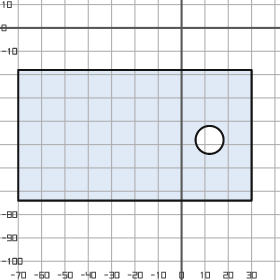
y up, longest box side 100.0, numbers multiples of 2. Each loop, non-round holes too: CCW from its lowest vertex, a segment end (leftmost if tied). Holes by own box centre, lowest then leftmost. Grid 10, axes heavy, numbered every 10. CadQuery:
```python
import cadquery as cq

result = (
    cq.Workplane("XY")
    .moveTo(-70.0, -74.0)
    .lineTo(30.0, -74.0)
    .lineTo(30.0, -18.0)
    .lineTo(-70.0, -18.0)
    .close()
    .moveTo(12.0, -48.0)
    .circle(6.0)
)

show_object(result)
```